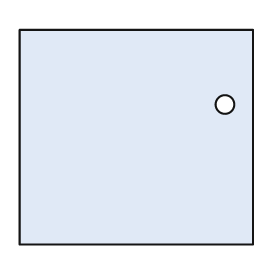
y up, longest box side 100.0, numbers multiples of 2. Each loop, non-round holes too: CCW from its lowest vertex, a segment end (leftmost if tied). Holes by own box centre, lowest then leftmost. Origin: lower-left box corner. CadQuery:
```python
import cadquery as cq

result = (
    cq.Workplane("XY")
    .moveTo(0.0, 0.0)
    .lineTo(100.0, 0.0)
    .lineTo(100.0, 92.0)
    .lineTo(0.0, 92.0)
    .close()
    .moveTo(88.0, 60.0)
    .circle(4.0)
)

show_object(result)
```